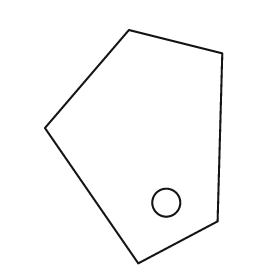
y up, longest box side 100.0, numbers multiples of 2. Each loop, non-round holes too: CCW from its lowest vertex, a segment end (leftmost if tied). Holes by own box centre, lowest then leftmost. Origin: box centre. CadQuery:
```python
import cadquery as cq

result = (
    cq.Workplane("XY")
    .moveTo(2.0, -50.0)
    .lineTo(36.0, -32.0)
    .lineTo(38.0, 40.0)
    .lineTo(-2.0, 50.0)
    .lineTo(-38.0, 8.0)
    .close()
    .moveTo(14.0, -24.0)
    .circle(6.0)
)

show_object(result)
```